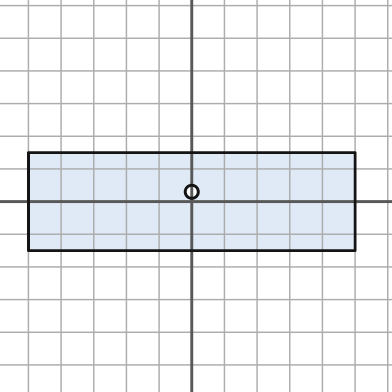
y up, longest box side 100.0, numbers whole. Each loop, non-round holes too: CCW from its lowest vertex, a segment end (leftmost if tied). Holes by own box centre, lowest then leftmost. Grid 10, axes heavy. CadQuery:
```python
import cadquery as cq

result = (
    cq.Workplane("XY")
    .moveTo(-50.0, -15.0)
    .lineTo(50.0, -15.0)
    .lineTo(50.0, 15.0)
    .lineTo(-50.0, 15.0)
    .close()
    .moveTo(0.0, 3.0)
    .circle(2.0)
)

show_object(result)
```